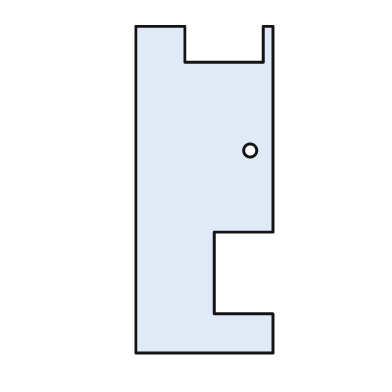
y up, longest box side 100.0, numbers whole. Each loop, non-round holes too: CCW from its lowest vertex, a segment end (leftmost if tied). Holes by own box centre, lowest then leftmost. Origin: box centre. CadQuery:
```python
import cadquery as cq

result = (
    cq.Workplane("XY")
    .moveTo(-21.0, -50.0)
    .lineTo(21.0, -50.0)
    .lineTo(21.0, -38.0)
    .lineTo(3.0, -38.0)
    .lineTo(3.0, -13.0)
    .lineTo(21.0, -13.0)
    .lineTo(21.0, 50.0)
    .lineTo(18.0, 50.0)
    .lineTo(18.0, 39.0)
    .lineTo(-6.0, 39.0)
    .lineTo(-6.0, 50.0)
    .lineTo(-21.0, 50.0)
    .close()
    .moveTo(14.0, 12.0)
    .circle(2.0)
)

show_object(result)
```